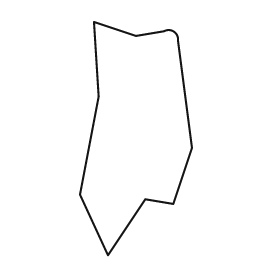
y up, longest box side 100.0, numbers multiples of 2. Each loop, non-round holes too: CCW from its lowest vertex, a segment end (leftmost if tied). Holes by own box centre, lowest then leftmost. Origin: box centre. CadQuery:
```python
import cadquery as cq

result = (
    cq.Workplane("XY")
    .moveTo(-12.0, -50.0)
    .lineTo(4.0, -26.0)
    .lineTo(16.0, -28.0)
    .lineTo(24.0, -4.0)
    .lineTo(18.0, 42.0)
    .threePointArc((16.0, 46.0), (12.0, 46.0))
    .lineTo(0.0, 44.0)
    .lineTo(-18.0, 50.0)
    .lineTo(-16.0, 18.0)
    .lineTo(-24.0, -24.0)
    .close()
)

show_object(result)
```